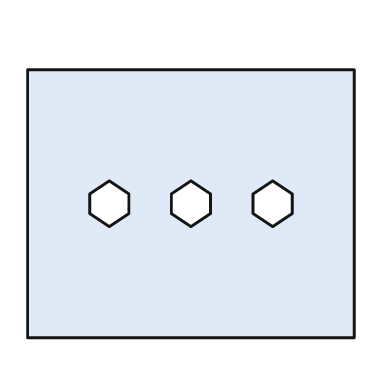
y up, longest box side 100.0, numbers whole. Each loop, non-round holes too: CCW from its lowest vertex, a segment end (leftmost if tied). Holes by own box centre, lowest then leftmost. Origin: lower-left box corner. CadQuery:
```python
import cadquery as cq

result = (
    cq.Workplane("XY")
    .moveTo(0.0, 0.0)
    .lineTo(100.0, 0.0)
    .lineTo(100.0, 82.0)
    .lineTo(0.0, 82.0)
    .close()
    .moveTo(25.0, 34.0)
    .lineTo(31.0, 38.0)
    .lineTo(31.0, 44.0)
    .lineTo(25.0, 48.0)
    .lineTo(19.0, 44.0)
    .lineTo(19.0, 38.0)
    .close()
    .moveTo(50.0, 34.0)
    .lineTo(56.0, 38.0)
    .lineTo(56.0, 44.0)
    .lineTo(50.0, 48.0)
    .lineTo(44.0, 44.0)
    .lineTo(44.0, 38.0)
    .close()
    .moveTo(75.0, 34.0)
    .lineTo(81.0, 38.0)
    .lineTo(81.0, 44.0)
    .lineTo(75.0, 48.0)
    .lineTo(69.0, 44.0)
    .lineTo(69.0, 38.0)
    .close()
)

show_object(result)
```